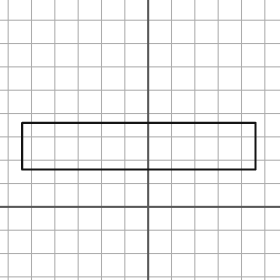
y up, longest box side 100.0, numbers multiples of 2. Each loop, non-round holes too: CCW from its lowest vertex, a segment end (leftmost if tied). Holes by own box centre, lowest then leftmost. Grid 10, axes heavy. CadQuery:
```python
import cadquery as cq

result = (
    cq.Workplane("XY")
    .moveTo(-54.0, 16.0)
    .lineTo(46.0, 16.0)
    .lineTo(46.0, 36.0)
    .lineTo(-54.0, 36.0)
    .close()
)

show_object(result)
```